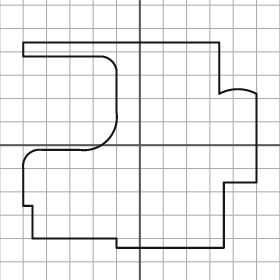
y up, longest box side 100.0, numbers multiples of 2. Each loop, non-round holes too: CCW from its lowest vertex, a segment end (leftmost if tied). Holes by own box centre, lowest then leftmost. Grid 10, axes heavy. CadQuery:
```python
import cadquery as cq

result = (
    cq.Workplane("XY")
    .moveTo(-10.0, -44.0)
    .lineTo(36.0, -44.0)
    .lineTo(36.0, -16.0)
    .lineTo(50.0, -16.0)
    .lineTo(50.0, 22.0)
    .threePointArc((42.0, 24.0), (34.0, 22.0))
    .lineTo(34.0, 44.0)
    .lineTo(-50.0, 44.0)
    .lineTo(-50.0, 38.0)
    .lineTo(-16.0, 38.0)
    .threePointArc((-12.0, 36.0), (-10.0, 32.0))
    .lineTo(-10.0, 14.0)
    .threePointArc((-14.0, 2.0), (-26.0, -2.0))
    .lineTo(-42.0, -2.0)
    .threePointArc((-48.0, -4.0), (-50.0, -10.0))
    .lineTo(-50.0, -26.0)
    .lineTo(-46.0, -26.0)
    .lineTo(-46.0, -40.0)
    .lineTo(-10.0, -40.0)
    .close()
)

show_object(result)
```